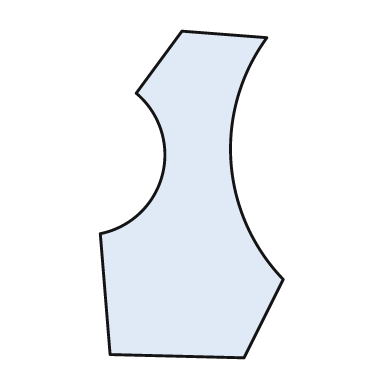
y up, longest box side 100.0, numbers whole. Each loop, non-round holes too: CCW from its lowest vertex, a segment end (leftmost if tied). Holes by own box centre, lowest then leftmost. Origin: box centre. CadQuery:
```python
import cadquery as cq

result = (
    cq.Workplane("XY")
    .moveTo(16.0, -50.0)
    .lineTo(28.0, -26.0)
    .threePointArc((12.0, 10.0), (23.0, 48.0))
    .lineTo(-3.0, 50.0)
    .lineTo(-17.0, 31.0)
    .threePointArc((-9.0, 6.0), (-28.0, -12.0))
    .lineTo(-25.0, -49.0)
    .close()
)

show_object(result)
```